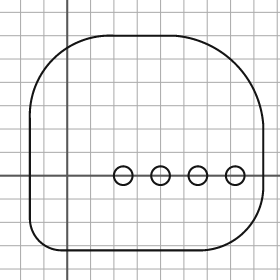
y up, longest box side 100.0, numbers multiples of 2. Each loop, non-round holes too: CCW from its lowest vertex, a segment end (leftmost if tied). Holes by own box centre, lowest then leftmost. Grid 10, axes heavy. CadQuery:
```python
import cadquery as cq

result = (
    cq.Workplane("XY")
    .moveTo(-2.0, -32.0)
    .lineTo(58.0, -32.0)
    .threePointArc((76.0, -24.0), (84.0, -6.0))
    .lineTo(84.0, 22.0)
    .threePointArc((72.0, 48.0), (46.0, 60.0))
    .lineTo(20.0, 60.0)
    .threePointArc((-6.0, 50.0), (-16.0, 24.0))
    .lineTo(-16.0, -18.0)
    .threePointArc((-12.0, -28.0), (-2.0, -32.0))
    .close()
    .moveTo(24.0, 0.0)
    .circle(4.0)
    .moveTo(40.0, 0.0)
    .circle(4.0)
    .moveTo(56.0, 0.0)
    .circle(4.0)
    .moveTo(72.0, 0.0)
    .circle(4.0)
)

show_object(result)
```